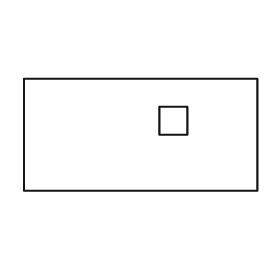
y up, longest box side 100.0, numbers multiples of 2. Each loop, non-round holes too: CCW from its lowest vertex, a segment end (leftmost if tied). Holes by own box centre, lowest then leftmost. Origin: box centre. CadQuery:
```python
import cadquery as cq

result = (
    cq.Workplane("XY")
    .moveTo(-50.0, -24.0)
    .lineTo(50.0, -24.0)
    .lineTo(50.0, 24.0)
    .lineTo(-50.0, 24.0)
    .close()
    .moveTo(8.0, 0.0)
    .lineTo(20.0, 0.0)
    .lineTo(20.0, 12.0)
    .lineTo(8.0, 12.0)
    .close()
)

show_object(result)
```